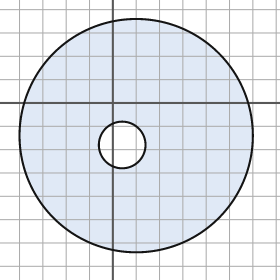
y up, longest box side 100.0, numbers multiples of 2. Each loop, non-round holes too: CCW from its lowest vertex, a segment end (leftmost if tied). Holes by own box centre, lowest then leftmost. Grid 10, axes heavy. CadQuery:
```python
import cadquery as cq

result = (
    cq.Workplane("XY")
    .moveTo(10.0, -14.0)
    .circle(50.0)
    .moveTo(4.0, -18.0)
    .circle(10.0)
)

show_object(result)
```